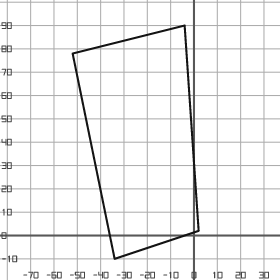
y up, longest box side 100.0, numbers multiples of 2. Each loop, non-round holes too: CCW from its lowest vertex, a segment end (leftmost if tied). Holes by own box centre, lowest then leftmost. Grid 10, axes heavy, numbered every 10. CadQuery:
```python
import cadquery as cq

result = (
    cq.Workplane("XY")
    .moveTo(-34.0, -10.0)
    .lineTo(2.0, 2.0)
    .lineTo(-4.0, 90.0)
    .lineTo(-52.0, 78.0)
    .close()
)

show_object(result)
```